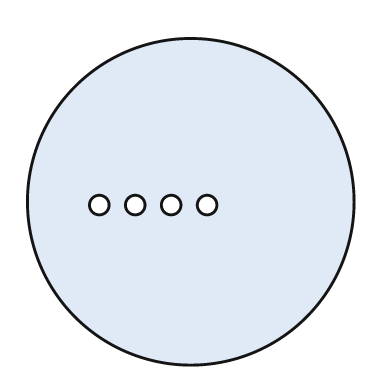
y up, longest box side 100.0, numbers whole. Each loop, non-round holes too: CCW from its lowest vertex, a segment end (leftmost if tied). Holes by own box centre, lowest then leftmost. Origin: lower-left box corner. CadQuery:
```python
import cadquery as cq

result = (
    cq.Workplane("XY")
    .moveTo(50.0, 50.0)
    .circle(50.0)
    .moveTo(22.0, 49.0)
    .circle(3.0)
    .moveTo(33.0, 49.0)
    .circle(3.0)
    .moveTo(44.0, 49.0)
    .circle(3.0)
    .moveTo(55.0, 49.0)
    .circle(3.0)
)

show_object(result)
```